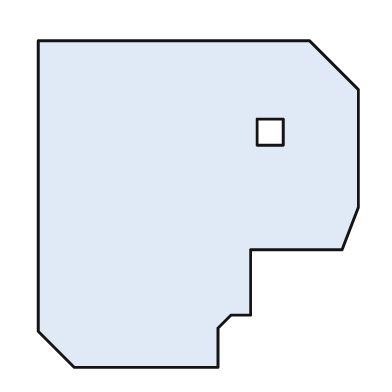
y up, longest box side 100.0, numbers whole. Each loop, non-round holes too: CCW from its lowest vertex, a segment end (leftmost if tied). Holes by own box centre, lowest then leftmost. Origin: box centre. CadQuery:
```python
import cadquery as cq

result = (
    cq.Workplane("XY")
    .moveTo(-38.0, -50.0)
    .lineTo(6.0, -50.0)
    .lineTo(6.0, -38.0)
    .lineTo(10.0, -34.0)
    .lineTo(16.0, -34.0)
    .lineTo(16.0, -14.0)
    .lineTo(44.0, -14.0)
    .lineTo(49.0, -1.0)
    .lineTo(49.0, 35.0)
    .lineTo(34.0, 50.0)
    .lineTo(-49.0, 50.0)
    .lineTo(-49.0, -39.0)
    .close()
    .moveTo(18.0, 18.0)
    .lineTo(26.0, 18.0)
    .lineTo(26.0, 26.0)
    .lineTo(18.0, 26.0)
    .close()
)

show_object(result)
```